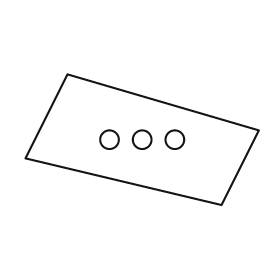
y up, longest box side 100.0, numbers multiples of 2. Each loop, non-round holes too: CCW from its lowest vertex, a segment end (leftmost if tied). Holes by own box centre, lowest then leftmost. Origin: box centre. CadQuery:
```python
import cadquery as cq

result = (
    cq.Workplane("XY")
    .moveTo(34.0, -28.0)
    .lineTo(50.0, 4.0)
    .lineTo(-32.0, 28.0)
    .lineTo(-50.0, -8.0)
    .close()
    .moveTo(-14.0, 0.0)
    .circle(4.0)
    .moveTo(0.0, 0.0)
    .circle(4.0)
    .moveTo(14.0, 0.0)
    .circle(4.0)
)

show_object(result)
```